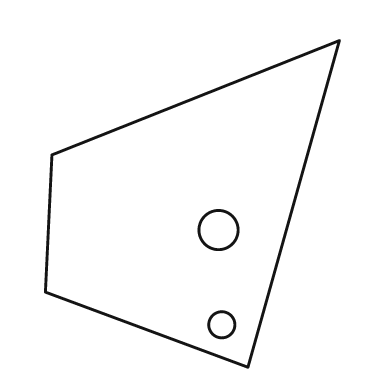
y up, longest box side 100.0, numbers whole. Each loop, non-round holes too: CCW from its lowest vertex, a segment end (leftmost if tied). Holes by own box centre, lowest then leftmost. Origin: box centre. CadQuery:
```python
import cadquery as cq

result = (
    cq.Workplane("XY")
    .moveTo(17.0, -50.0)
    .lineTo(45.0, 50.0)
    .lineTo(-43.0, 15.0)
    .lineTo(-45.0, -27.0)
    .close()
    .moveTo(9.0, -37.0)
    .circle(4.0)
    .moveTo(8.0, -8.0)
    .circle(6.0)
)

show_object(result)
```